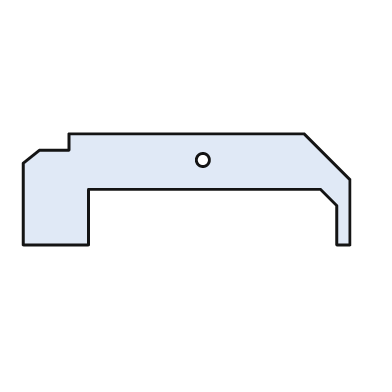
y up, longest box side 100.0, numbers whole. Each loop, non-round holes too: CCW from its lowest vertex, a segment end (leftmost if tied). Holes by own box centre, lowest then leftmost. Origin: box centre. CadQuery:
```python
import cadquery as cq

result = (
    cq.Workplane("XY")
    .moveTo(-50.0, -17.0)
    .lineTo(-30.0, -17.0)
    .lineTo(-30.0, 0.0)
    .lineTo(41.0, 0.0)
    .lineTo(46.0, -5.0)
    .lineTo(46.0, -17.0)
    .lineTo(50.0, -17.0)
    .lineTo(50.0, 3.0)
    .lineTo(36.0, 17.0)
    .lineTo(-36.0, 17.0)
    .lineTo(-36.0, 12.0)
    .lineTo(-45.0, 12.0)
    .lineTo(-50.0, 8.0)
    .close()
    .moveTo(5.0, 9.0)
    .circle(2.0)
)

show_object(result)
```